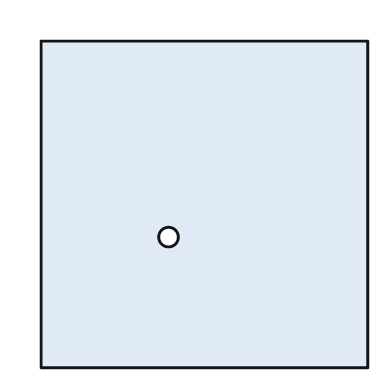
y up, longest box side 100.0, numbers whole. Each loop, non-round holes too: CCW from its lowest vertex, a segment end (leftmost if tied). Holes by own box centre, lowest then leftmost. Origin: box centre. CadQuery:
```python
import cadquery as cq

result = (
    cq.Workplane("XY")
    .moveTo(-50.0, -50.0)
    .lineTo(50.0, -50.0)
    .lineTo(50.0, 50.0)
    .lineTo(-50.0, 50.0)
    .close()
    .moveTo(-11.0, -10.0)
    .circle(3.0)
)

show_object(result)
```